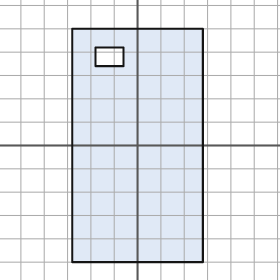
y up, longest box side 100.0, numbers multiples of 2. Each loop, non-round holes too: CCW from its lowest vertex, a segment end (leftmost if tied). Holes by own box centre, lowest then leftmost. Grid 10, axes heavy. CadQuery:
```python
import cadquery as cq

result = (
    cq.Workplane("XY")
    .moveTo(-28.0, -50.0)
    .lineTo(28.0, -50.0)
    .lineTo(28.0, 50.0)
    .lineTo(-28.0, 50.0)
    .close()
    .moveTo(-18.0, 34.0)
    .lineTo(-6.0, 34.0)
    .lineTo(-6.0, 42.0)
    .lineTo(-18.0, 42.0)
    .close()
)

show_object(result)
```